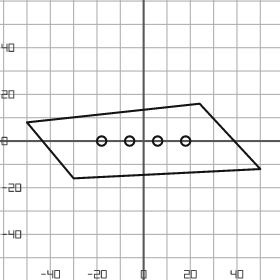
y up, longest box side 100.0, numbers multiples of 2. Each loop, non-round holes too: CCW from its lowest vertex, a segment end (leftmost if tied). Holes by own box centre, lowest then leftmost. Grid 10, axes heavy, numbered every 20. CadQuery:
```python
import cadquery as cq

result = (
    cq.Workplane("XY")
    .moveTo(-30.0, -16.0)
    .lineTo(50.0, -12.0)
    .lineTo(24.0, 16.0)
    .lineTo(-50.0, 8.0)
    .close()
    .moveTo(-18.0, 0.0)
    .circle(2.0)
    .moveTo(-6.0, 0.0)
    .circle(2.0)
    .moveTo(6.0, 0.0)
    .circle(2.0)
    .moveTo(18.0, 0.0)
    .circle(2.0)
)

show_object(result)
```